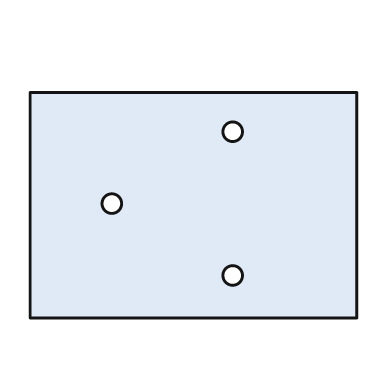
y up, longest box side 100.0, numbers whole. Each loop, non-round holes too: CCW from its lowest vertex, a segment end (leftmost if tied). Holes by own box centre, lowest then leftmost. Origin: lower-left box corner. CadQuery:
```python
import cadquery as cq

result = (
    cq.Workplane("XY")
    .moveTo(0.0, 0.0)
    .lineTo(100.0, 0.0)
    .lineTo(100.0, 69.0)
    .lineTo(0.0, 69.0)
    .close()
    .moveTo(62.0, 13.0)
    .circle(3.0)
    .moveTo(25.0, 35.0)
    .circle(3.0)
    .moveTo(62.0, 57.0)
    .circle(3.0)
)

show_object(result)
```